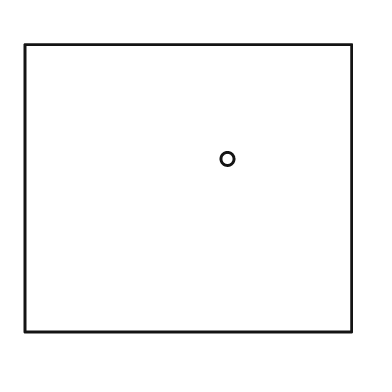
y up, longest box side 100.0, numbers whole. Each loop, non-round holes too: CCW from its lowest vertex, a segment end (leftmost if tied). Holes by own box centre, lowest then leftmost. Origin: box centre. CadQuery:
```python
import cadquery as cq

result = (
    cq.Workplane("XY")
    .moveTo(-50.0, -44.0)
    .lineTo(50.0, -44.0)
    .lineTo(50.0, 44.0)
    .lineTo(-50.0, 44.0)
    .close()
    .moveTo(12.0, 9.0)
    .circle(2.0)
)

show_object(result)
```